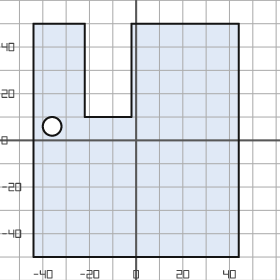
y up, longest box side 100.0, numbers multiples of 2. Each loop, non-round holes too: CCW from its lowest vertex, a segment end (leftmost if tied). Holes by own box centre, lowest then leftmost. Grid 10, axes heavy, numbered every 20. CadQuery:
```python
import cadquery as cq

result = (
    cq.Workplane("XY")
    .moveTo(-44.0, -50.0)
    .lineTo(44.0, -50.0)
    .lineTo(44.0, 50.0)
    .lineTo(-2.0, 50.0)
    .lineTo(-2.0, 10.0)
    .lineTo(-22.0, 10.0)
    .lineTo(-22.0, 50.0)
    .lineTo(-44.0, 50.0)
    .close()
    .moveTo(-36.0, 6.0)
    .circle(4.0)
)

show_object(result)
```